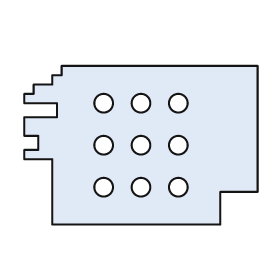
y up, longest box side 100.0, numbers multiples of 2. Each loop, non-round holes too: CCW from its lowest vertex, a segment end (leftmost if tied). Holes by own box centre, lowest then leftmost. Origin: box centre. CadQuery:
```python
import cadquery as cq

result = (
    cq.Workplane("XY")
    .moveTo(-38.0, -34.0)
    .lineTo(34.0, -34.0)
    .lineTo(34.0, -20.0)
    .lineTo(50.0, -20.0)
    .lineTo(50.0, 34.0)
    .lineTo(-34.0, 34.0)
    .lineTo(-34.0, 30.0)
    .lineTo(-38.0, 30.0)
    .lineTo(-38.0, 26.0)
    .lineTo(-46.0, 26.0)
    .lineTo(-46.0, 22.0)
    .lineTo(-50.0, 22.0)
    .lineTo(-50.0, 18.0)
    .lineTo(-36.0, 18.0)
    .lineTo(-36.0, 12.0)
    .lineTo(-50.0, 12.0)
    .lineTo(-50.0, 4.0)
    .lineTo(-44.0, 4.0)
    .lineTo(-44.0, -2.0)
    .lineTo(-50.0, -2.0)
    .lineTo(-50.0, -6.0)
    .lineTo(-38.0, -6.0)
    .close()
    .moveTo(-16.0, -18.0)
    .circle(4.0)
    .moveTo(0.0, -18.0)
    .circle(4.0)
    .moveTo(16.0, -18.0)
    .circle(4.0)
    .moveTo(-16.0, 0.0)
    .circle(4.0)
    .moveTo(0.0, 0.0)
    .circle(4.0)
    .moveTo(16.0, 0.0)
    .circle(4.0)
    .moveTo(-16.0, 18.0)
    .circle(4.0)
    .moveTo(0.0, 18.0)
    .circle(4.0)
    .moveTo(16.0, 18.0)
    .circle(4.0)
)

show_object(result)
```